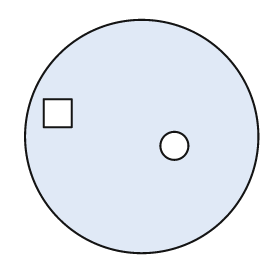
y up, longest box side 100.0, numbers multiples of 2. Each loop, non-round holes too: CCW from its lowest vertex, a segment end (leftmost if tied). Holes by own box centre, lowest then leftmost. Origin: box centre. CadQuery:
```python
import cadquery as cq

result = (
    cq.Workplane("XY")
    .moveTo(0.0, 0.0)
    .circle(50.0)
    .moveTo(14.0, -4.0)
    .circle(6.0)
    .moveTo(-42.0, 4.0)
    .lineTo(-30.0, 4.0)
    .lineTo(-30.0, 16.0)
    .lineTo(-42.0, 16.0)
    .close()
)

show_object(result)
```